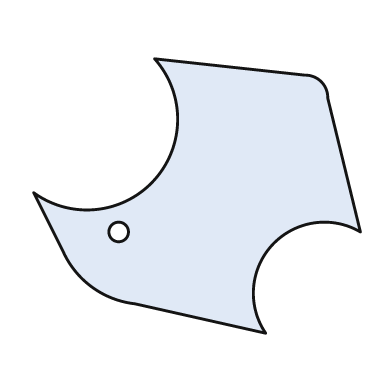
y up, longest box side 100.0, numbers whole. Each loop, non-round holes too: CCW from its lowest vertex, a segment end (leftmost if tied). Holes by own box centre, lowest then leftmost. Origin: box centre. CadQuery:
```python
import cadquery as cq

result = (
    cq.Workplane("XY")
    .moveTo(21.0, -42.0)
    .threePointArc((23.0, -15.0), (50.0, -11.0))
    .lineTo(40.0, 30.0)
    .threePointArc((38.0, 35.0), (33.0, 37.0))
    .lineTo(-13.0, 42.0)
    .threePointArc((-13.0, 5.0), (-50.0, 1.0))
    .lineTo(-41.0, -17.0)
    .threePointArc((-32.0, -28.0), (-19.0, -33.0))
    .close()
    .moveTo(-24.0, -11.0)
    .circle(3.0)
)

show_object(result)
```